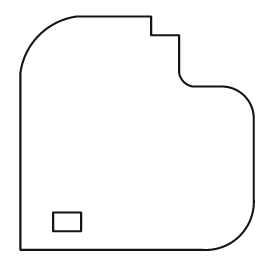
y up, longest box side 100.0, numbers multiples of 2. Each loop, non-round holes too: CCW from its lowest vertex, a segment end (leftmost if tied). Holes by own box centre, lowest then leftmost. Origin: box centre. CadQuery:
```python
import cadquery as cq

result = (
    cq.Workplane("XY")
    .moveTo(-50.0, -50.0)
    .lineTo(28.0, -50.0)
    .threePointArc((44.0, -44.0), (50.0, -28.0))
    .lineTo(50.0, 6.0)
    .threePointArc((46.0, 16.0), (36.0, 20.0))
    .lineTo(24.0, 20.0)
    .threePointArc((20.0, 22.0), (18.0, 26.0))
    .lineTo(18.0, 42.0)
    .lineTo(6.0, 42.0)
    .lineTo(6.0, 50.0)
    .lineTo(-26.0, 50.0)
    .threePointArc((-42.0, 42.0), (-50.0, 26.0))
    .close()
    .moveTo(-36.0, -42.0)
    .lineTo(-24.0, -42.0)
    .lineTo(-24.0, -34.0)
    .lineTo(-36.0, -34.0)
    .close()
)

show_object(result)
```